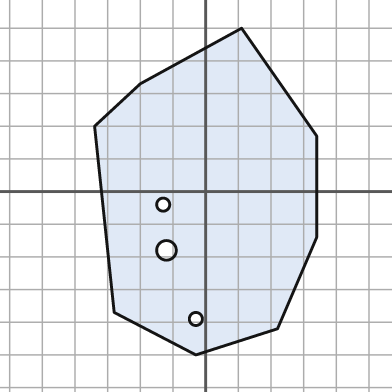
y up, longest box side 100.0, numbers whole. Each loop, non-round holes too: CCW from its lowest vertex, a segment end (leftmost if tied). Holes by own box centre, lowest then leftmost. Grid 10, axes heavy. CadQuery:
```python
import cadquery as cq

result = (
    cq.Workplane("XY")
    .moveTo(-3.0, -50.0)
    .lineTo(22.0, -42.0)
    .lineTo(34.0, -14.0)
    .lineTo(34.0, 17.0)
    .lineTo(11.0, 50.0)
    .lineTo(-20.0, 33.0)
    .lineTo(-34.0, 20.0)
    .lineTo(-28.0, -37.0)
    .close()
    .moveTo(-3.0, -39.0)
    .circle(2.0)
    .moveTo(-12.0, -18.0)
    .circle(3.0)
    .moveTo(-13.0, -4.0)
    .circle(2.0)
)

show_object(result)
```